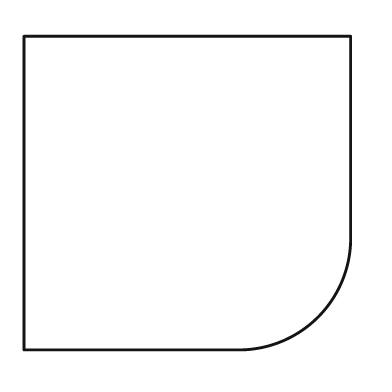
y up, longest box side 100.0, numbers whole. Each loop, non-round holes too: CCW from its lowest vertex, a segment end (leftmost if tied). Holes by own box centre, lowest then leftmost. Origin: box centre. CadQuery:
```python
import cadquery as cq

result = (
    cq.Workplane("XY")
    .moveTo(-50.0, -48.0)
    .lineTo(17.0, -48.0)
    .threePointArc((40.0, -38.0), (50.0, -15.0))
    .lineTo(50.0, 48.0)
    .lineTo(-50.0, 48.0)
    .close()
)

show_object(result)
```